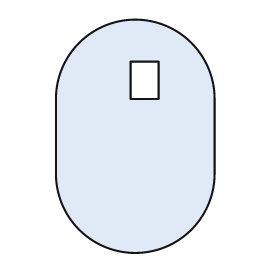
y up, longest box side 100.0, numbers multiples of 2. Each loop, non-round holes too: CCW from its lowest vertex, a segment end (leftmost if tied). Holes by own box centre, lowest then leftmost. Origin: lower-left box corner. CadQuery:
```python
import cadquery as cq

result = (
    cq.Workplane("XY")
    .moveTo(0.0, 34.0)
    .threePointArc((34.0, 0.0), (68.0, 34.0))
    .lineTo(68.0, 66.0)
    .threePointArc((34.0, 100.0), (0.0, 66.0))
    .close()
    .moveTo(32.0, 66.0)
    .lineTo(44.0, 66.0)
    .lineTo(44.0, 82.0)
    .lineTo(32.0, 82.0)
    .close()
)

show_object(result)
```